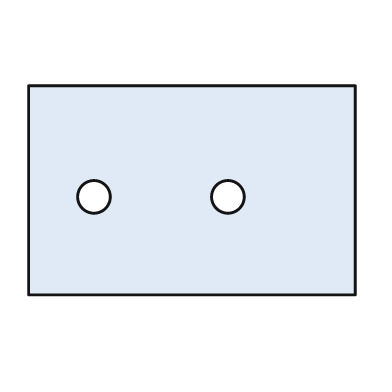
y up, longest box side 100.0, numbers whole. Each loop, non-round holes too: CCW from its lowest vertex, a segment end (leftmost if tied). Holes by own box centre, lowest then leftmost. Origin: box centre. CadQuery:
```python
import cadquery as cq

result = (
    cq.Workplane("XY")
    .moveTo(-50.0, -32.0)
    .lineTo(50.0, -32.0)
    .lineTo(50.0, 32.0)
    .lineTo(-50.0, 32.0)
    .close()
    .moveTo(-30.0, -2.0)
    .circle(5.0)
    .moveTo(11.0, -2.0)
    .circle(5.0)
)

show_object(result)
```